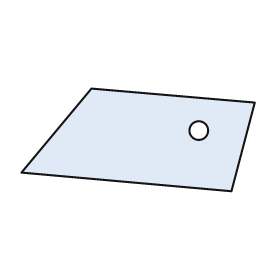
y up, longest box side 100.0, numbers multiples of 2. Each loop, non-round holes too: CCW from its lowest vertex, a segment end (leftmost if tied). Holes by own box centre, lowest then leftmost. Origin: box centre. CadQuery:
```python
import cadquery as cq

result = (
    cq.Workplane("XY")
    .moveTo(40.0, -22.0)
    .lineTo(50.0, 16.0)
    .lineTo(-20.0, 22.0)
    .lineTo(-50.0, -14.0)
    .close()
    .moveTo(26.0, 4.0)
    .circle(4.0)
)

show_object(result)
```